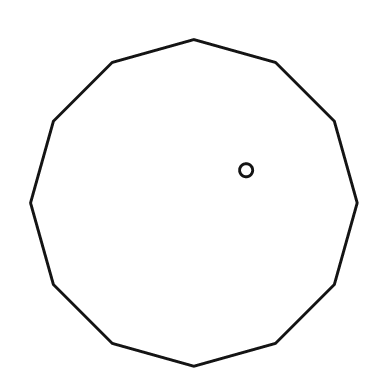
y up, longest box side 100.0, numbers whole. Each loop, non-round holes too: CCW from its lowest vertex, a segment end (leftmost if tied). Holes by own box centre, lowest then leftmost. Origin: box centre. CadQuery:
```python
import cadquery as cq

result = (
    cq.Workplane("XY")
    .moveTo(0.0, -50.0)
    .lineTo(25.0, -43.0)
    .lineTo(43.0, -25.0)
    .lineTo(50.0, 0.0)
    .lineTo(43.0, 25.0)
    .lineTo(25.0, 43.0)
    .lineTo(0.0, 50.0)
    .lineTo(-25.0, 43.0)
    .lineTo(-43.0, 25.0)
    .lineTo(-50.0, 0.0)
    .lineTo(-43.0, -25.0)
    .lineTo(-25.0, -43.0)
    .close()
    .moveTo(16.0, 10.0)
    .circle(2.0)
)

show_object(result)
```